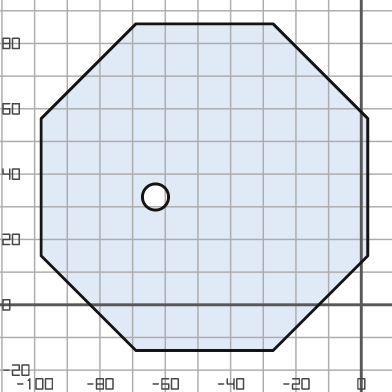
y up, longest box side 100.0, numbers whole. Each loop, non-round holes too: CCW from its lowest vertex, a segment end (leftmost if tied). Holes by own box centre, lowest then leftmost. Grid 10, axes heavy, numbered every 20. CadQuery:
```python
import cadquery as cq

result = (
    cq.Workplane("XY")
    .moveTo(-69.0, -14.0)
    .lineTo(-27.0, -14.0)
    .lineTo(2.0, 15.0)
    .lineTo(2.0, 57.0)
    .lineTo(-27.0, 86.0)
    .lineTo(-69.0, 86.0)
    .lineTo(-98.0, 57.0)
    .lineTo(-98.0, 15.0)
    .close()
    .moveTo(-63.0, 33.0)
    .circle(4.0)
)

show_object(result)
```